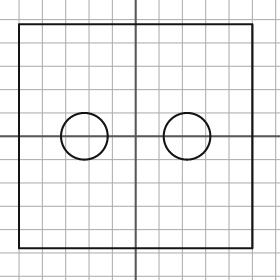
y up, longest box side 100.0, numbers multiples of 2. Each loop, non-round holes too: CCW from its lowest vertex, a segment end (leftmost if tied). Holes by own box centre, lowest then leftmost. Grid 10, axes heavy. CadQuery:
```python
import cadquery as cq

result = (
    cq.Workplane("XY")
    .moveTo(-50.0, -48.0)
    .lineTo(50.0, -48.0)
    .lineTo(50.0, 48.0)
    .lineTo(-50.0, 48.0)
    .close()
    .moveTo(-22.0, 0.0)
    .circle(10.0)
    .moveTo(22.0, 0.0)
    .circle(10.0)
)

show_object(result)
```